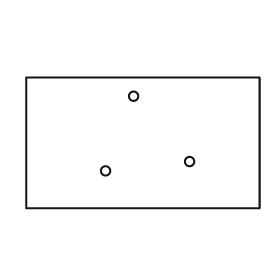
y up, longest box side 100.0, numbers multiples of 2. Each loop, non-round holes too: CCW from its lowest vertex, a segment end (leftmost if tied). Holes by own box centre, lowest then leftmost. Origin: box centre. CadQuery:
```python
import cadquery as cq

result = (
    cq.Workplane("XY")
    .moveTo(-50.0, -28.0)
    .lineTo(50.0, -28.0)
    .lineTo(50.0, 28.0)
    .lineTo(-50.0, 28.0)
    .close()
    .moveTo(-16.0, -12.0)
    .circle(2.0)
    .moveTo(20.0, -8.0)
    .circle(2.0)
    .moveTo(-4.0, 20.0)
    .circle(2.0)
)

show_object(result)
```